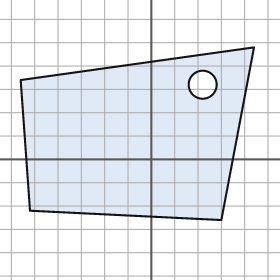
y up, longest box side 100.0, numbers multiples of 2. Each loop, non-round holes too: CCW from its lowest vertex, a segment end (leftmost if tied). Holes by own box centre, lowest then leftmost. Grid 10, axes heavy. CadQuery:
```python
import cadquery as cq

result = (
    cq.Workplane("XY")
    .moveTo(30.0, -26.0)
    .lineTo(44.0, 48.0)
    .lineTo(-56.0, 34.0)
    .lineTo(-52.0, -22.0)
    .close()
    .moveTo(22.0, 32.0)
    .circle(6.0)
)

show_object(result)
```